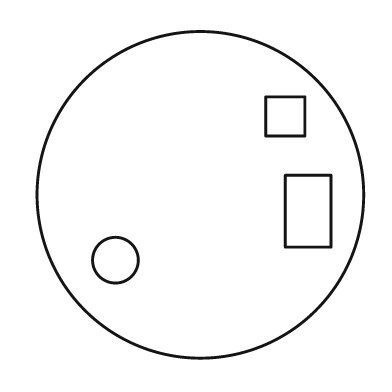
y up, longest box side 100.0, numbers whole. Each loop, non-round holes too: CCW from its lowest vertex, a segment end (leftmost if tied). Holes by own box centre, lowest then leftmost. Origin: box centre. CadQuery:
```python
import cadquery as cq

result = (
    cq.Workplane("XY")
    .moveTo(0.0, 0.0)
    .circle(50.0)
    .moveTo(-26.0, -20.0)
    .circle(7.0)
    .moveTo(26.0, -16.0)
    .lineTo(40.0, -16.0)
    .lineTo(40.0, 6.0)
    .lineTo(26.0, 6.0)
    .close()
    .moveTo(20.0, 18.0)
    .lineTo(32.0, 18.0)
    .lineTo(32.0, 30.0)
    .lineTo(20.0, 30.0)
    .close()
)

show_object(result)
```